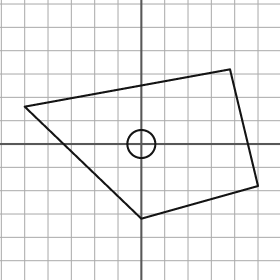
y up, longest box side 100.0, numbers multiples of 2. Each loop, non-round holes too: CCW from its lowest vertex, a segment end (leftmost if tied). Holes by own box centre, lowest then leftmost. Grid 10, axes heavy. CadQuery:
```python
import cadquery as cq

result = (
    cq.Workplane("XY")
    .moveTo(0.0, -32.0)
    .lineTo(50.0, -18.0)
    .lineTo(38.0, 32.0)
    .lineTo(-50.0, 16.0)
    .close()
    .moveTo(0.0, 0.0)
    .circle(6.0)
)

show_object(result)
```